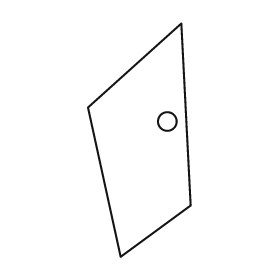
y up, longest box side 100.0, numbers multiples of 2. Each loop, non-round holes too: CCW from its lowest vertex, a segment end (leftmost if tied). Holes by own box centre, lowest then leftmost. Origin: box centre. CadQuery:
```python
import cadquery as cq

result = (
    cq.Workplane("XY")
    .moveTo(-8.0, -50.0)
    .lineTo(22.0, -28.0)
    .lineTo(18.0, 50.0)
    .lineTo(-22.0, 14.0)
    .close()
    .moveTo(12.0, 8.0)
    .circle(4.0)
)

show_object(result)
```